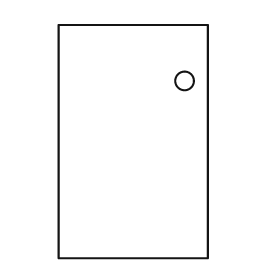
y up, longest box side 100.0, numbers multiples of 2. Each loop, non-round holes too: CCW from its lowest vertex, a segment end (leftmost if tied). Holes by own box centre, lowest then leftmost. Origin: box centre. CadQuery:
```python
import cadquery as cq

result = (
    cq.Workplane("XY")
    .moveTo(-32.0, -50.0)
    .lineTo(32.0, -50.0)
    .lineTo(32.0, 50.0)
    .lineTo(-32.0, 50.0)
    .close()
    .moveTo(22.0, 26.0)
    .circle(4.0)
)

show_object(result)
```